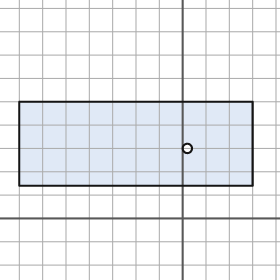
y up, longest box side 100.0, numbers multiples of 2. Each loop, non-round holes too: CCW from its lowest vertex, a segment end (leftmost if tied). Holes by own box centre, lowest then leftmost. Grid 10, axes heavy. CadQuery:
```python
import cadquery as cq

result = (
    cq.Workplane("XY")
    .moveTo(-70.0, 14.0)
    .lineTo(30.0, 14.0)
    .lineTo(30.0, 50.0)
    .lineTo(-70.0, 50.0)
    .close()
    .moveTo(2.0, 30.0)
    .circle(2.0)
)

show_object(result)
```